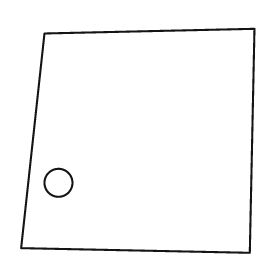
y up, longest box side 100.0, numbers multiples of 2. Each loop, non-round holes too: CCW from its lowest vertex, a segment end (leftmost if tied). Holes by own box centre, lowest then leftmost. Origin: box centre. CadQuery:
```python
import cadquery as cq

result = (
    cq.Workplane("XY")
    .moveTo(48.0, -48.0)
    .lineTo(50.0, 48.0)
    .lineTo(-40.0, 46.0)
    .lineTo(-50.0, -46.0)
    .close()
    .moveTo(-34.0, -18.0)
    .circle(6.0)
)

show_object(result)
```